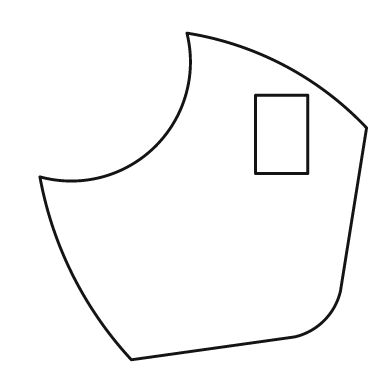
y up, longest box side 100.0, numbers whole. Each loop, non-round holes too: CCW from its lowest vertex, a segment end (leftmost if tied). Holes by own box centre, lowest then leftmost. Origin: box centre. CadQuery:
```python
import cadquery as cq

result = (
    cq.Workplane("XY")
    .moveTo(-22.0, -50.0)
    .lineTo(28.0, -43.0)
    .threePointArc((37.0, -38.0), (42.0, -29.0))
    .lineTo(50.0, 21.0)
    .threePointArc((25.0, 40.0), (-5.0, 50.0))
    .threePointArc((-15.0, 15.0), (-50.0, 6.0))
    .threePointArc((-40.0, -24.0), (-22.0, -50.0))
    .close()
    .moveTo(16.0, 7.0)
    .lineTo(32.0, 7.0)
    .lineTo(32.0, 31.0)
    .lineTo(16.0, 31.0)
    .close()
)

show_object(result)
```